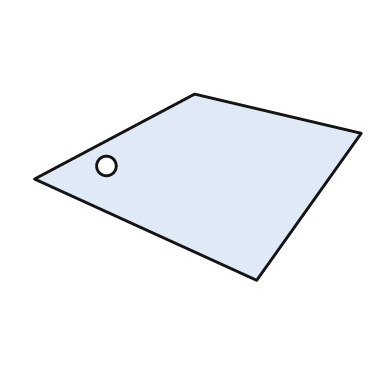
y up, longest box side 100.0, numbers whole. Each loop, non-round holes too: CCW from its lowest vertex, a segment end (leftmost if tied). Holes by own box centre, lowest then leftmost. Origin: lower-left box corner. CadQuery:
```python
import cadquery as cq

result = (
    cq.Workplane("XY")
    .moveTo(68.0, 0.0)
    .lineTo(100.0, 45.0)
    .lineTo(49.0, 57.0)
    .lineTo(0.0, 31.0)
    .close()
    .moveTo(22.0, 35.0)
    .circle(3.0)
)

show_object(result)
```